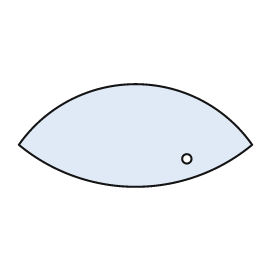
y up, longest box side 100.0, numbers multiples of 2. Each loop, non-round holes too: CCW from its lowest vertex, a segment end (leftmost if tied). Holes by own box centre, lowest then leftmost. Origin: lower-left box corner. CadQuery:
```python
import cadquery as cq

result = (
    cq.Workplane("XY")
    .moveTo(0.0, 18.0)
    .threePointArc((50.0, 0.0), (100.0, 18.0))
    .threePointArc((50.0, 44.0), (0.0, 18.0))
    .close()
    .moveTo(72.0, 12.0)
    .circle(2.0)
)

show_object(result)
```